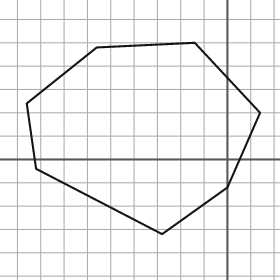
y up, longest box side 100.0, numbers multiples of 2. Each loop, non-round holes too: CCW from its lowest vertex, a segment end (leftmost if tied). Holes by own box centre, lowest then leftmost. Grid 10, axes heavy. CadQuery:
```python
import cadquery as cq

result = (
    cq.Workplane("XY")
    .moveTo(-28.0, -32.0)
    .lineTo(0.0, -12.0)
    .lineTo(14.0, 20.0)
    .lineTo(-14.0, 50.0)
    .lineTo(-56.0, 48.0)
    .lineTo(-86.0, 24.0)
    .lineTo(-82.0, -4.0)
    .close()
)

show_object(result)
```